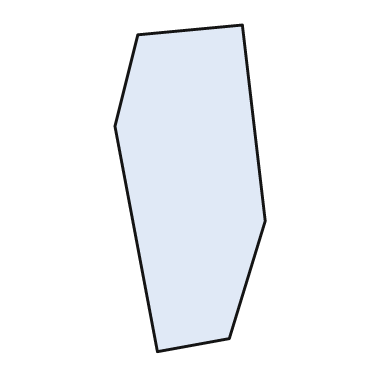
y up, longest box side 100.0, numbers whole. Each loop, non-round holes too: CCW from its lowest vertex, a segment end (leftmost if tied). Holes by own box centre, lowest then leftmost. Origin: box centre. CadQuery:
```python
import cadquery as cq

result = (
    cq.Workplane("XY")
    .moveTo(-10.0, -50.0)
    .lineTo(12.0, -46.0)
    .lineTo(23.0, -10.0)
    .lineTo(16.0, 50.0)
    .lineTo(-16.0, 47.0)
    .lineTo(-23.0, 19.0)
    .close()
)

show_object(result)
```